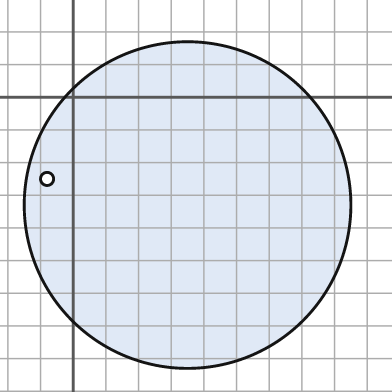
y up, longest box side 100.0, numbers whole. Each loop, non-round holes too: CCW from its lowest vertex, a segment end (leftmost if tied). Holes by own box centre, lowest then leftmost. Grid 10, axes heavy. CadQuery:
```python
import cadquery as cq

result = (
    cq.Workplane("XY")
    .moveTo(35.0, -33.0)
    .circle(50.0)
    .moveTo(-8.0, -25.0)
    .circle(2.0)
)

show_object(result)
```